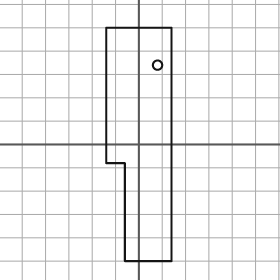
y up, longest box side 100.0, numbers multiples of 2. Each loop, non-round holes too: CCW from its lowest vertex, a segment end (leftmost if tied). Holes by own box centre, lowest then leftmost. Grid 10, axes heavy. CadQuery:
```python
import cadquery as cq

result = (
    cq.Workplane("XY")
    .moveTo(-6.0, -50.0)
    .lineTo(14.0, -50.0)
    .lineTo(14.0, 50.0)
    .lineTo(-14.0, 50.0)
    .lineTo(-14.0, -8.0)
    .lineTo(-6.0, -8.0)
    .close()
    .moveTo(8.0, 34.0)
    .circle(2.0)
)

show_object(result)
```